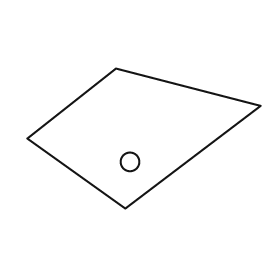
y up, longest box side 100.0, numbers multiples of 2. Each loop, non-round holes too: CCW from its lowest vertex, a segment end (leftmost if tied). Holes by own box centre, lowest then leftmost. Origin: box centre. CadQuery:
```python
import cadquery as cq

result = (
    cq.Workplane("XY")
    .moveTo(-8.0, -30.0)
    .lineTo(50.0, 14.0)
    .lineTo(-12.0, 30.0)
    .lineTo(-50.0, 0.0)
    .close()
    .moveTo(-6.0, -10.0)
    .circle(4.0)
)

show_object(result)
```